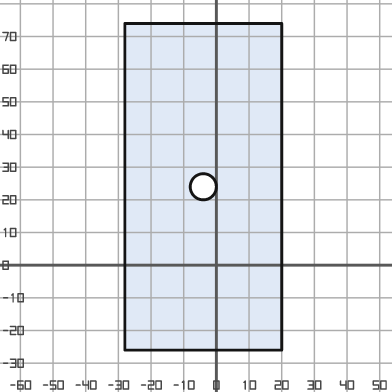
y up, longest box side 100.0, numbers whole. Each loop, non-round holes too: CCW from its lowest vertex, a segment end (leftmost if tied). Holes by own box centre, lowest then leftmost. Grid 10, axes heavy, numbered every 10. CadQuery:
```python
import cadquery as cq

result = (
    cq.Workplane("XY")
    .moveTo(-28.0, -26.0)
    .lineTo(20.0, -26.0)
    .lineTo(20.0, 74.0)
    .lineTo(-28.0, 74.0)
    .close()
    .moveTo(-4.0, 24.0)
    .circle(4.0)
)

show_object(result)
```